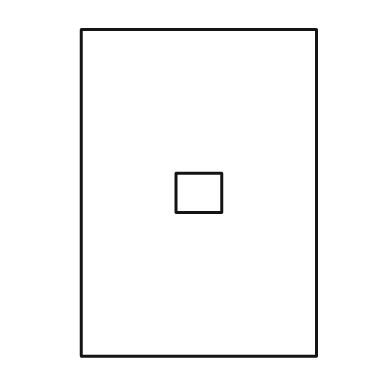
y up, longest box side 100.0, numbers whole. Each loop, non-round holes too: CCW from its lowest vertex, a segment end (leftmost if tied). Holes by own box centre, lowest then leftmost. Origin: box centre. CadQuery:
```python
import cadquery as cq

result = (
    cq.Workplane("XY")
    .moveTo(-36.0, -50.0)
    .lineTo(36.0, -50.0)
    .lineTo(36.0, 50.0)
    .lineTo(-36.0, 50.0)
    .close()
    .moveTo(-7.0, -6.0)
    .lineTo(7.0, -6.0)
    .lineTo(7.0, 6.0)
    .lineTo(-7.0, 6.0)
    .close()
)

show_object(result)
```